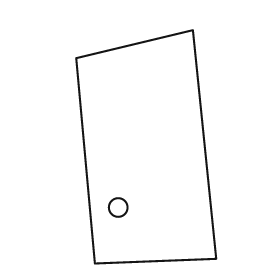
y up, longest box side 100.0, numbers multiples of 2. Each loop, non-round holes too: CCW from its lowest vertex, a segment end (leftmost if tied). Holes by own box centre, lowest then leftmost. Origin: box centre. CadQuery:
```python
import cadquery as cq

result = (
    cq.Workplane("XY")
    .moveTo(-22.0, -50.0)
    .lineTo(30.0, -48.0)
    .lineTo(20.0, 50.0)
    .lineTo(-30.0, 38.0)
    .close()
    .moveTo(-12.0, -26.0)
    .circle(4.0)
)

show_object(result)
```